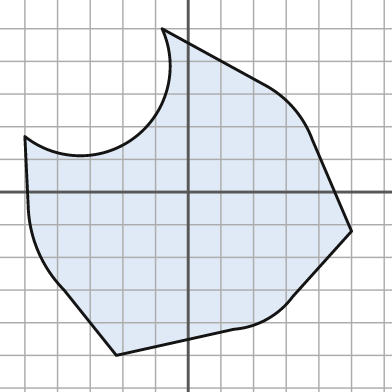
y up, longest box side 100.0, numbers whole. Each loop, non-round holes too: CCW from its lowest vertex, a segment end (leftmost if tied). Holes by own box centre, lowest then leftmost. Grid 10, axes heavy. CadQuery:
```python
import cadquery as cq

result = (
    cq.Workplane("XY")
    .moveTo(-22.0, -50.0)
    .lineTo(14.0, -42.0)
    .threePointArc((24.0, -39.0), (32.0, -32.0))
    .lineTo(50.0, -12.0)
    .lineTo(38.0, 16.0)
    .threePointArc((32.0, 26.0), (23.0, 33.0))
    .lineTo(-8.0, 50.0)
    .threePointArc((-16.0, 17.0), (-50.0, 17.0))
    .lineTo(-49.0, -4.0)
    .threePointArc((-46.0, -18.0), (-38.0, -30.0))
    .close()
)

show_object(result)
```